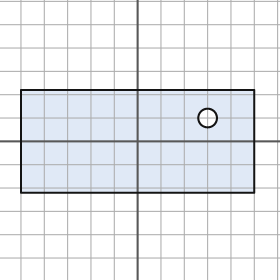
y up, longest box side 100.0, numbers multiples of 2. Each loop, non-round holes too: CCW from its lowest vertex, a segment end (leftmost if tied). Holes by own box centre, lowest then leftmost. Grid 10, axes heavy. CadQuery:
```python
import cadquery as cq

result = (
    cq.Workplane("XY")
    .moveTo(-50.0, -22.0)
    .lineTo(50.0, -22.0)
    .lineTo(50.0, 22.0)
    .lineTo(-50.0, 22.0)
    .close()
    .moveTo(30.0, 10.0)
    .circle(4.0)
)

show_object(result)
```